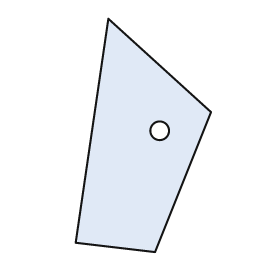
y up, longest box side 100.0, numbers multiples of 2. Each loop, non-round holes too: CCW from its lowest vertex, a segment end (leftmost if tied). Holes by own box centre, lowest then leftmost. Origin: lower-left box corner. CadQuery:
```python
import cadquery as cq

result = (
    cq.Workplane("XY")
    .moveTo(34.0, 0.0)
    .lineTo(58.0, 60.0)
    .lineTo(14.0, 100.0)
    .lineTo(0.0, 4.0)
    .close()
    .moveTo(36.0, 52.0)
    .circle(4.0)
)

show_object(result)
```